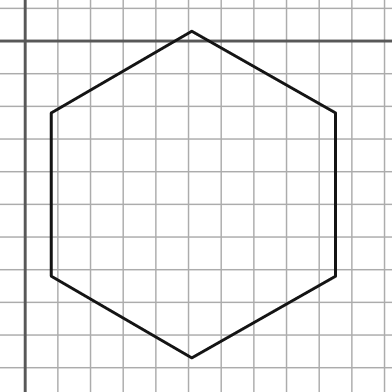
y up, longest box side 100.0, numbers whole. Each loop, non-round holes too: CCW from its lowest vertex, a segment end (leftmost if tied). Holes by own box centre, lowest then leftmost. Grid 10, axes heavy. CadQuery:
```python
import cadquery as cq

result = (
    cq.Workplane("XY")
    .moveTo(51.0, -97.0)
    .lineTo(95.0, -72.0)
    .lineTo(95.0, -22.0)
    .lineTo(51.0, 3.0)
    .lineTo(8.0, -22.0)
    .lineTo(8.0, -72.0)
    .close()
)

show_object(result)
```